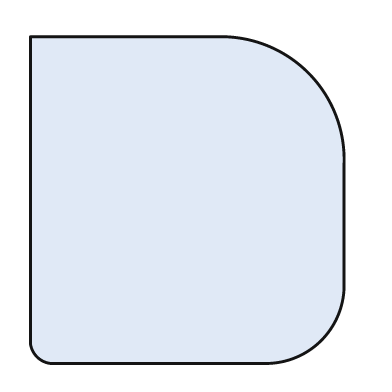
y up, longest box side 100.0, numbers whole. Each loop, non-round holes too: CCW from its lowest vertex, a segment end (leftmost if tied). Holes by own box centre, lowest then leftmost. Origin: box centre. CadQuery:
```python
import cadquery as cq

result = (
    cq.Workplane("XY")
    .moveTo(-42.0, -50.0)
    .lineTo(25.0, -50.0)
    .threePointArc((41.0, -43.0), (48.0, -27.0))
    .lineTo(48.0, 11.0)
    .threePointArc((37.0, 39.0), (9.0, 50.0))
    .lineTo(-48.0, 50.0)
    .lineTo(-48.0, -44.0)
    .threePointArc((-46.0, -48.0), (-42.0, -50.0))
    .close()
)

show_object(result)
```